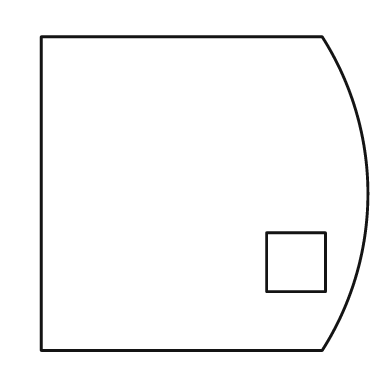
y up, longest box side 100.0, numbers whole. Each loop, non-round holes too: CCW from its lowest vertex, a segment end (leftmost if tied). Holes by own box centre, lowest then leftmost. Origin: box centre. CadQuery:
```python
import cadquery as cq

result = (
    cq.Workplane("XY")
    .moveTo(-50.0, -48.0)
    .lineTo(36.0, -48.0)
    .threePointArc((50.0, 0.0), (36.0, 48.0))
    .lineTo(-50.0, 48.0)
    .close()
    .moveTo(19.0, -30.0)
    .lineTo(37.0, -30.0)
    .lineTo(37.0, -12.0)
    .lineTo(19.0, -12.0)
    .close()
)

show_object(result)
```